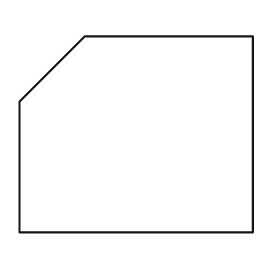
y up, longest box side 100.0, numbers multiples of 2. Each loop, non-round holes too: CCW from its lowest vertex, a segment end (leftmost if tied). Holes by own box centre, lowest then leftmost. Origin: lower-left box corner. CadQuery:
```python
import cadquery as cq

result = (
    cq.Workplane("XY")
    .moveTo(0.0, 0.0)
    .lineTo(100.0, 0.0)
    .lineTo(100.0, 84.0)
    .lineTo(28.0, 84.0)
    .lineTo(0.0, 56.0)
    .close()
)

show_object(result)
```